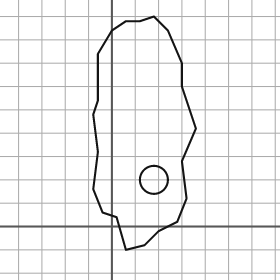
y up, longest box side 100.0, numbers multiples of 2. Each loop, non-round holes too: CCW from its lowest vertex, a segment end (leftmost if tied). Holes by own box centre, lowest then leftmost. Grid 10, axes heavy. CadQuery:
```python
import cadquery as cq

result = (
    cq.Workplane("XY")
    .moveTo(6.0, -10.0)
    .lineTo(14.0, -8.0)
    .lineTo(20.0, -2.0)
    .lineTo(28.0, 2.0)
    .lineTo(32.0, 12.0)
    .lineTo(30.0, 28.0)
    .lineTo(36.0, 42.0)
    .lineTo(30.0, 60.0)
    .lineTo(30.0, 70.0)
    .lineTo(24.0, 84.0)
    .lineTo(18.0, 90.0)
    .lineTo(12.0, 88.0)
    .lineTo(6.0, 88.0)
    .lineTo(0.0, 84.0)
    .lineTo(-6.0, 74.0)
    .lineTo(-6.0, 54.0)
    .lineTo(-8.0, 48.0)
    .lineTo(-6.0, 32.0)
    .lineTo(-8.0, 16.0)
    .lineTo(-4.0, 6.0)
    .lineTo(2.0, 4.0)
    .close()
    .moveTo(18.0, 20.0)
    .circle(6.0)
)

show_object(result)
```